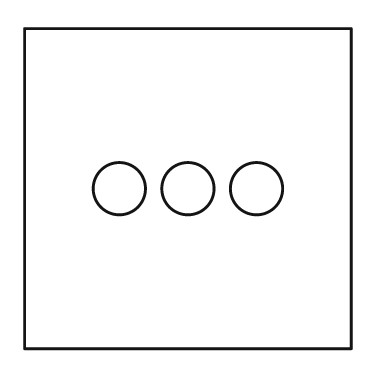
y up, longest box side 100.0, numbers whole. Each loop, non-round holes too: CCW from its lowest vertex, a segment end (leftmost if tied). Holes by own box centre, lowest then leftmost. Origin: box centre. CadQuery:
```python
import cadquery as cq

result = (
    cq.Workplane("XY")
    .moveTo(-50.0, -49.0)
    .lineTo(50.0, -49.0)
    .lineTo(50.0, 49.0)
    .lineTo(-50.0, 49.0)
    .close()
    .moveTo(-21.0, 0.0)
    .circle(8.0)
    .moveTo(0.0, 0.0)
    .circle(8.0)
    .moveTo(21.0, 0.0)
    .circle(8.0)
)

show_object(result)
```